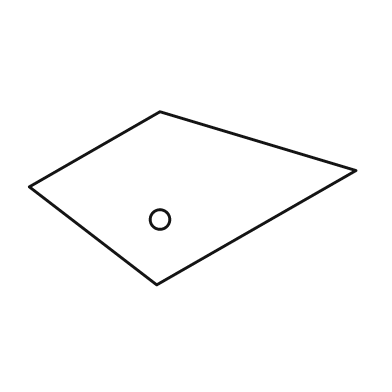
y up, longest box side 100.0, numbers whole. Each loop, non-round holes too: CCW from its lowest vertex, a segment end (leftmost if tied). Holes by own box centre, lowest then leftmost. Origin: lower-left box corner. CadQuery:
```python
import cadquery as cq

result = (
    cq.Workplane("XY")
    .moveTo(39.0, 0.0)
    .lineTo(100.0, 35.0)
    .lineTo(40.0, 53.0)
    .lineTo(0.0, 30.0)
    .close()
    .moveTo(40.0, 20.0)
    .circle(3.0)
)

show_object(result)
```